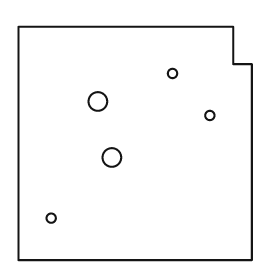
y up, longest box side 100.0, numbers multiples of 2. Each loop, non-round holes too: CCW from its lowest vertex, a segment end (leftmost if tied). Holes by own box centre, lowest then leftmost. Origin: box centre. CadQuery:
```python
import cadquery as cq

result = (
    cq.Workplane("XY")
    .moveTo(-50.0, -50.0)
    .lineTo(50.0, -50.0)
    .lineTo(50.0, 34.0)
    .lineTo(42.0, 34.0)
    .lineTo(42.0, 50.0)
    .lineTo(-50.0, 50.0)
    .close()
    .moveTo(-36.0, -32.0)
    .circle(2.0)
    .moveTo(-10.0, -6.0)
    .circle(4.0)
    .moveTo(32.0, 12.0)
    .circle(2.0)
    .moveTo(-16.0, 18.0)
    .circle(4.0)
    .moveTo(16.0, 30.0)
    .circle(2.0)
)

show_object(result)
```